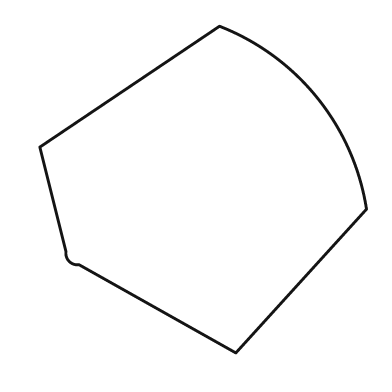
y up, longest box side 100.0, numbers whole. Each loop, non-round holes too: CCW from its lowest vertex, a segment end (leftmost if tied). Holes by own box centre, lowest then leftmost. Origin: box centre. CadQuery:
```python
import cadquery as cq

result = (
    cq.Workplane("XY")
    .moveTo(10.0, -50.0)
    .lineTo(50.0, -6.0)
    .threePointArc((35.0, 28.0), (5.0, 50.0))
    .lineTo(-50.0, 13.0)
    .lineTo(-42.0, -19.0)
    .threePointArc((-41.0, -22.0), (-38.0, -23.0))
    .close()
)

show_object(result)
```